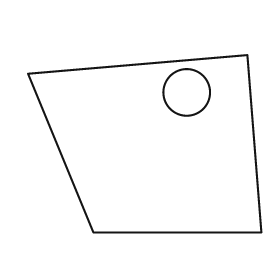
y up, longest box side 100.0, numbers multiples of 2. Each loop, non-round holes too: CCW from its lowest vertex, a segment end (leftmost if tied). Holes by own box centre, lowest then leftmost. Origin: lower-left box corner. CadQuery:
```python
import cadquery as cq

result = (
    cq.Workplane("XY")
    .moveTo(28.0, 0.0)
    .lineTo(100.0, 0.0)
    .lineTo(94.0, 76.0)
    .lineTo(0.0, 68.0)
    .close()
    .moveTo(68.0, 60.0)
    .circle(10.0)
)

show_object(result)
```